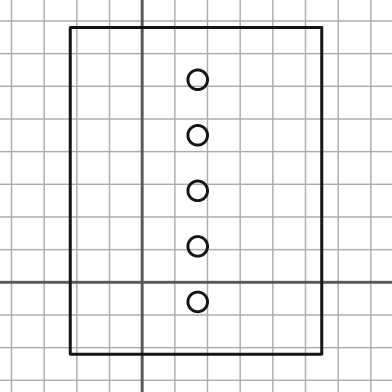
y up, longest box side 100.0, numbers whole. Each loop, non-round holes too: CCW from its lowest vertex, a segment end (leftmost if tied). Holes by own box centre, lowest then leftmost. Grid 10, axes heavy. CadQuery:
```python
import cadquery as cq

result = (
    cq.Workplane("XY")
    .moveTo(-22.0, -22.0)
    .lineTo(55.0, -22.0)
    .lineTo(55.0, 78.0)
    .lineTo(-22.0, 78.0)
    .close()
    .moveTo(17.0, -6.0)
    .circle(3.0)
    .moveTo(17.0, 11.0)
    .circle(3.0)
    .moveTo(17.0, 28.0)
    .circle(3.0)
    .moveTo(17.0, 45.0)
    .circle(3.0)
    .moveTo(17.0, 62.0)
    .circle(3.0)
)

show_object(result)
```